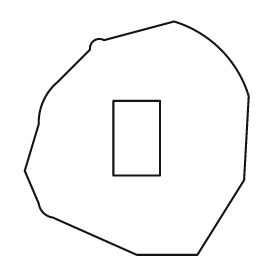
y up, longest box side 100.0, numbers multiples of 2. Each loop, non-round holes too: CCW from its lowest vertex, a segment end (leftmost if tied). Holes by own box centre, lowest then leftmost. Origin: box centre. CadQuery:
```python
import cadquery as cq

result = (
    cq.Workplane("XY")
    .moveTo(0.0, -50.0)
    .lineTo(26.0, -50.0)
    .lineTo(46.0, -18.0)
    .lineTo(48.0, 18.0)
    .threePointArc((36.0, 38.0), (16.0, 50.0))
    .lineTo(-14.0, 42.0)
    .threePointArc((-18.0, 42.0), (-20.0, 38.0))
    .lineTo(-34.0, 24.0)
    .threePointArc((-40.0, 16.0), (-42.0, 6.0))
    .lineTo(-48.0, -14.0)
    .lineTo(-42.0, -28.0)
    .threePointArc((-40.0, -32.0), (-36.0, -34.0))
    .close()
    .moveTo(-10.0, -16.0)
    .lineTo(10.0, -16.0)
    .lineTo(10.0, 16.0)
    .lineTo(-10.0, 16.0)
    .close()
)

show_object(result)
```